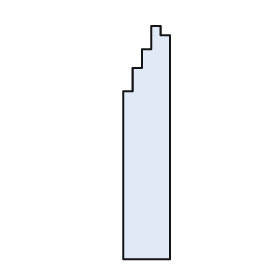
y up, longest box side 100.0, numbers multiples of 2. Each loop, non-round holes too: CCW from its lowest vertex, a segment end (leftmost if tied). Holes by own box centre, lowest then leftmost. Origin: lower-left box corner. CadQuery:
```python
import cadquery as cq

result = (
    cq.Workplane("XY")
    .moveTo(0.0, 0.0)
    .lineTo(20.0, 0.0)
    .lineTo(20.0, 96.0)
    .lineTo(16.0, 96.0)
    .lineTo(16.0, 100.0)
    .lineTo(12.0, 100.0)
    .lineTo(12.0, 90.0)
    .lineTo(8.0, 90.0)
    .lineTo(8.0, 82.0)
    .lineTo(4.0, 82.0)
    .lineTo(4.0, 72.0)
    .lineTo(0.0, 72.0)
    .close()
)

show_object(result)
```